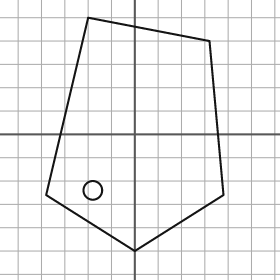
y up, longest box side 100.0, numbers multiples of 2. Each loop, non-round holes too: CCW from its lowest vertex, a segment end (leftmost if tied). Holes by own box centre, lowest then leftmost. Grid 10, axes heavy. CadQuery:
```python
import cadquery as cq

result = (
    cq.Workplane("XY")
    .moveTo(0.0, -50.0)
    .lineTo(38.0, -26.0)
    .lineTo(32.0, 40.0)
    .lineTo(-20.0, 50.0)
    .lineTo(-38.0, -26.0)
    .close()
    .moveTo(-18.0, -24.0)
    .circle(4.0)
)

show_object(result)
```